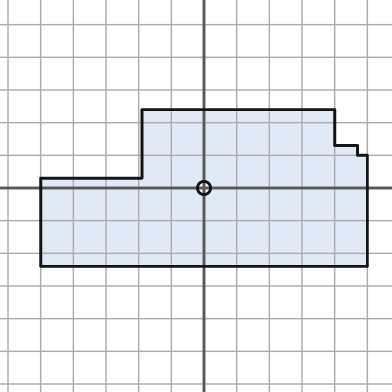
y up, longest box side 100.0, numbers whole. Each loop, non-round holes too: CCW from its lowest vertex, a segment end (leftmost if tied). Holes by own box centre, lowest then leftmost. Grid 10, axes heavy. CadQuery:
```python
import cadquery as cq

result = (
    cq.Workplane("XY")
    .moveTo(-50.0, -24.0)
    .lineTo(50.0, -24.0)
    .lineTo(50.0, 10.0)
    .lineTo(47.0, 10.0)
    .lineTo(47.0, 13.0)
    .lineTo(40.0, 13.0)
    .lineTo(40.0, 24.0)
    .lineTo(-19.0, 24.0)
    .lineTo(-19.0, 3.0)
    .lineTo(-50.0, 3.0)
    .close()
    .moveTo(0.0, 0.0)
    .circle(2.0)
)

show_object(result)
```